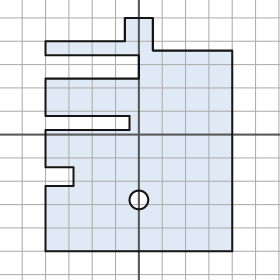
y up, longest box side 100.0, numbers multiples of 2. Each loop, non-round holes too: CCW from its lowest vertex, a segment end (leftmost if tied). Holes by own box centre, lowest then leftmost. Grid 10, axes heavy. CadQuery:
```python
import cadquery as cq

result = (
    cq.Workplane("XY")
    .moveTo(-40.0, -50.0)
    .lineTo(40.0, -50.0)
    .lineTo(40.0, 36.0)
    .lineTo(6.0, 36.0)
    .lineTo(6.0, 50.0)
    .lineTo(-6.0, 50.0)
    .lineTo(-6.0, 40.0)
    .lineTo(-40.0, 40.0)
    .lineTo(-40.0, 34.0)
    .lineTo(0.0, 34.0)
    .lineTo(0.0, 24.0)
    .lineTo(-40.0, 24.0)
    .lineTo(-40.0, 8.0)
    .lineTo(-4.0, 8.0)
    .lineTo(-4.0, 2.0)
    .lineTo(-40.0, 2.0)
    .lineTo(-40.0, -14.0)
    .lineTo(-28.0, -14.0)
    .lineTo(-28.0, -22.0)
    .lineTo(-40.0, -22.0)
    .close()
    .moveTo(0.0, -28.0)
    .circle(4.0)
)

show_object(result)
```